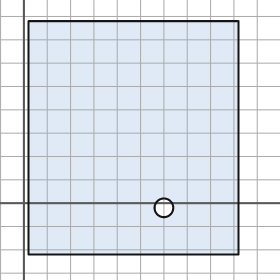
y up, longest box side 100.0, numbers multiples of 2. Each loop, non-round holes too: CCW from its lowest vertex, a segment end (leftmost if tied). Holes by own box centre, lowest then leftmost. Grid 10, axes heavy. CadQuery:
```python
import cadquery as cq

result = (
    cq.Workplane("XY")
    .moveTo(2.0, -22.0)
    .lineTo(92.0, -22.0)
    .lineTo(92.0, 78.0)
    .lineTo(2.0, 78.0)
    .close()
    .moveTo(60.0, -2.0)
    .circle(4.0)
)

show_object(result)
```